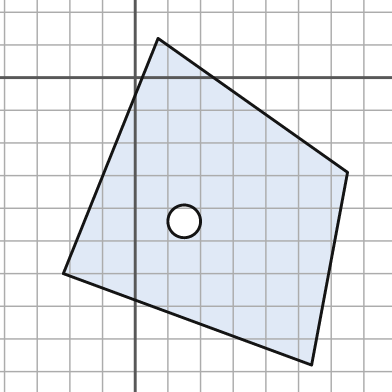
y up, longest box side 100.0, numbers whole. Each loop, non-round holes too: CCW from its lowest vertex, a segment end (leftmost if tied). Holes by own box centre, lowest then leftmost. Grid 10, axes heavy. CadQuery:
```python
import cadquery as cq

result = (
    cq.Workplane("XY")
    .moveTo(54.0, -88.0)
    .lineTo(65.0, -29.0)
    .lineTo(7.0, 12.0)
    .lineTo(-22.0, -60.0)
    .close()
    .moveTo(15.0, -44.0)
    .circle(5.0)
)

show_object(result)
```